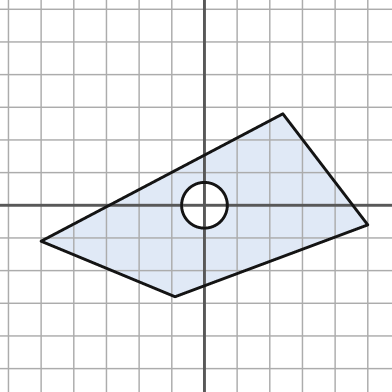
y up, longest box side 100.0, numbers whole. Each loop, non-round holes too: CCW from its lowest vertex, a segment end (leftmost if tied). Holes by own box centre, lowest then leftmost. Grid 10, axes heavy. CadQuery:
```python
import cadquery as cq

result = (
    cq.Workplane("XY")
    .moveTo(-9.0, -28.0)
    .lineTo(50.0, -6.0)
    .lineTo(24.0, 28.0)
    .lineTo(-50.0, -11.0)
    .close()
    .moveTo(0.0, 0.0)
    .circle(7.0)
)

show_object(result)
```